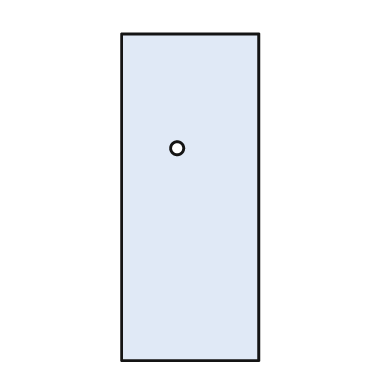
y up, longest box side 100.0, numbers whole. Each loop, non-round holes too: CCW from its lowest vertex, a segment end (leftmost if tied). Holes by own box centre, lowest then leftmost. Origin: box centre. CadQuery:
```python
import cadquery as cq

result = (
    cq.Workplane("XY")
    .moveTo(-21.0, -50.0)
    .lineTo(21.0, -50.0)
    .lineTo(21.0, 50.0)
    .lineTo(-21.0, 50.0)
    .close()
    .moveTo(-4.0, 15.0)
    .circle(2.0)
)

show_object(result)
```